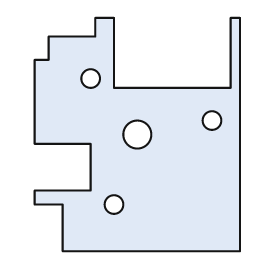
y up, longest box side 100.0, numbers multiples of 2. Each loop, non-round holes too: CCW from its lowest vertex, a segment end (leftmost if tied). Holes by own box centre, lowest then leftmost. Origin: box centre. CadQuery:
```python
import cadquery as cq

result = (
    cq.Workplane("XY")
    .moveTo(-32.0, -50.0)
    .lineTo(44.0, -50.0)
    .lineTo(44.0, 50.0)
    .lineTo(40.0, 50.0)
    .lineTo(40.0, 20.0)
    .lineTo(-10.0, 20.0)
    .lineTo(-10.0, 50.0)
    .lineTo(-18.0, 50.0)
    .lineTo(-18.0, 42.0)
    .lineTo(-38.0, 42.0)
    .lineTo(-38.0, 32.0)
    .lineTo(-44.0, 32.0)
    .lineTo(-44.0, -4.0)
    .lineTo(-20.0, -4.0)
    .lineTo(-20.0, -24.0)
    .lineTo(-44.0, -24.0)
    .lineTo(-44.0, -30.0)
    .lineTo(-32.0, -30.0)
    .close()
    .moveTo(-10.0, -30.0)
    .circle(4.0)
    .moveTo(0.0, 0.0)
    .circle(6.0)
    .moveTo(32.0, 6.0)
    .circle(4.0)
    .moveTo(-20.0, 24.0)
    .circle(4.0)
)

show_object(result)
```